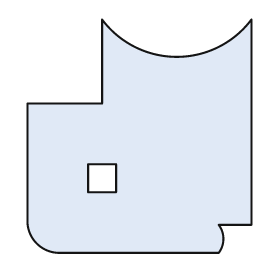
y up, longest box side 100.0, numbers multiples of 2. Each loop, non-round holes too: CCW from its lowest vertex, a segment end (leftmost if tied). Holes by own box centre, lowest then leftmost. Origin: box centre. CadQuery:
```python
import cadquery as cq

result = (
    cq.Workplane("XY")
    .moveTo(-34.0, -50.0)
    .lineTo(34.0, -50.0)
    .threePointArc((36.0, -44.0), (34.0, -38.0))
    .lineTo(48.0, -38.0)
    .lineTo(48.0, 50.0)
    .threePointArc((16.0, 34.0), (-16.0, 50.0))
    .lineTo(-16.0, 14.0)
    .lineTo(-48.0, 14.0)
    .lineTo(-48.0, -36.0)
    .threePointArc((-44.0, -46.0), (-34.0, -50.0))
    .close()
    .moveTo(-22.0, -24.0)
    .lineTo(-10.0, -24.0)
    .lineTo(-10.0, -12.0)
    .lineTo(-22.0, -12.0)
    .close()
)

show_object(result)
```